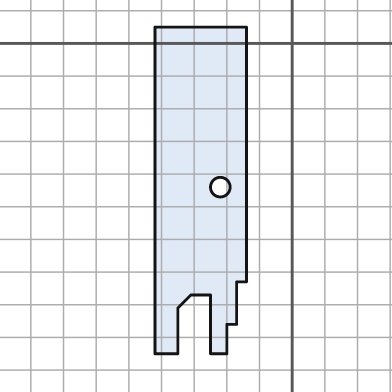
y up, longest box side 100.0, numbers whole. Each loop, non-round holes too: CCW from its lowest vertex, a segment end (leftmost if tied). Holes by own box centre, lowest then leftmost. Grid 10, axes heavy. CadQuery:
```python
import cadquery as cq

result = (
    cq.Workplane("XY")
    .moveTo(-42.0, -95.0)
    .lineTo(-35.0, -95.0)
    .lineTo(-35.0, -81.0)
    .lineTo(-31.0, -77.0)
    .lineTo(-25.0, -77.0)
    .lineTo(-25.0, -95.0)
    .lineTo(-20.0, -95.0)
    .lineTo(-20.0, -86.0)
    .lineTo(-17.0, -86.0)
    .lineTo(-17.0, -73.0)
    .lineTo(-14.0, -73.0)
    .lineTo(-14.0, 5.0)
    .lineTo(-42.0, 5.0)
    .close()
    .moveTo(-22.0, -44.0)
    .circle(3.0)
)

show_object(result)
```